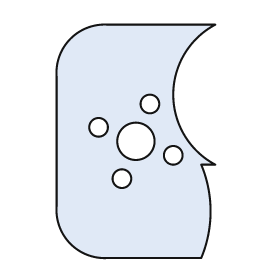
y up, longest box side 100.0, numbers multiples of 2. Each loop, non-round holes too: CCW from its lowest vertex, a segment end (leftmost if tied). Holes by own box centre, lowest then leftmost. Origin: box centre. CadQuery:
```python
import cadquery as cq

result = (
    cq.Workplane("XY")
    .moveTo(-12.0, -50.0)
    .lineTo(28.0, -50.0)
    .threePointArc((32.0, -30.0), (28.0, -10.0))
    .lineTo(34.0, -10.0)
    .threePointArc((16.0, 20.0), (34.0, 50.0))
    .lineTo(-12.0, 50.0)
    .threePointArc((-28.0, 44.0), (-34.0, 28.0))
    .lineTo(-34.0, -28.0)
    .threePointArc((-28.0, -44.0), (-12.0, -50.0))
    .close()
    .moveTo(-6.0, -16.0)
    .circle(4.0)
    .moveTo(16.0, -6.0)
    .circle(4.0)
    .moveTo(0.0, 0.0)
    .circle(8.0)
    .moveTo(-16.0, 6.0)
    .circle(4.0)
    .moveTo(6.0, 16.0)
    .circle(4.0)
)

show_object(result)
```